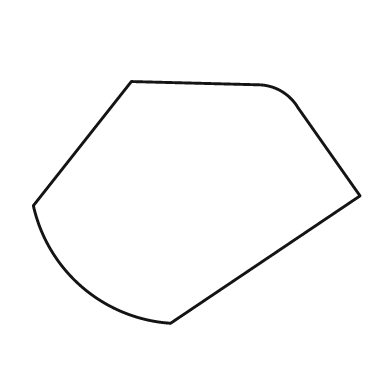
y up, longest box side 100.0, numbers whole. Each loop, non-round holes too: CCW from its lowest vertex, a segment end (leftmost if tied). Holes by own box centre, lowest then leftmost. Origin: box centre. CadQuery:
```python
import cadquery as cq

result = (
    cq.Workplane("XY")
    .moveTo(-8.0, -37.0)
    .lineTo(50.0, 2.0)
    .lineTo(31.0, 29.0)
    .threePointArc((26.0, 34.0), (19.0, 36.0))
    .lineTo(-20.0, 37.0)
    .lineTo(-50.0, -1.0)
    .threePointArc((-35.0, -26.0), (-8.0, -37.0))
    .close()
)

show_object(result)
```